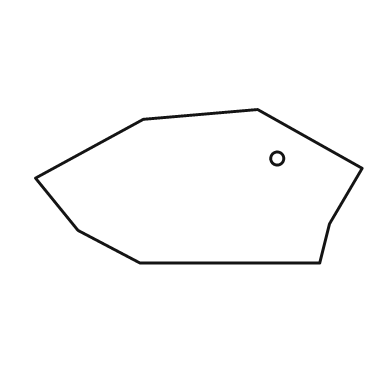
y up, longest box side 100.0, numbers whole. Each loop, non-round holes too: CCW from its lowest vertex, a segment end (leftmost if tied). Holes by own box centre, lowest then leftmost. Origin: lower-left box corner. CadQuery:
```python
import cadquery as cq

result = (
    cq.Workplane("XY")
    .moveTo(32.0, 0.0)
    .lineTo(87.0, 0.0)
    .lineTo(90.0, 12.0)
    .lineTo(100.0, 29.0)
    .lineTo(68.0, 47.0)
    .lineTo(33.0, 44.0)
    .lineTo(0.0, 26.0)
    .lineTo(13.0, 10.0)
    .close()
    .moveTo(74.0, 32.0)
    .circle(2.0)
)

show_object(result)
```